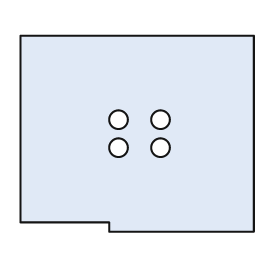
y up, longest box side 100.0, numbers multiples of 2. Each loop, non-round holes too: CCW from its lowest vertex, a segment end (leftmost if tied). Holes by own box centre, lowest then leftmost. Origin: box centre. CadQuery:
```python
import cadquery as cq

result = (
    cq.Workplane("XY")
    .moveTo(-12.0, -42.0)
    .lineTo(50.0, -42.0)
    .lineTo(50.0, 42.0)
    .lineTo(-50.0, 42.0)
    .lineTo(-50.0, -38.0)
    .lineTo(-12.0, -38.0)
    .close()
    .moveTo(-8.0, -6.0)
    .circle(4.0)
    .moveTo(10.0, -6.0)
    .circle(4.0)
    .moveTo(-8.0, 6.0)
    .circle(4.0)
    .moveTo(10.0, 6.0)
    .circle(4.0)
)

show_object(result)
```